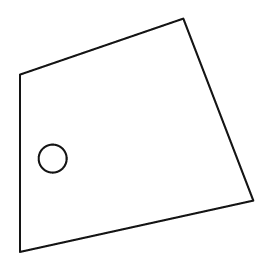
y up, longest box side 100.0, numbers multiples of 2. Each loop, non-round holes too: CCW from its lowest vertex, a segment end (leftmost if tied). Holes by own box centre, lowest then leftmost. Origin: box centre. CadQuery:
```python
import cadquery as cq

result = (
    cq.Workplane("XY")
    .moveTo(-50.0, -50.0)
    .lineTo(50.0, -28.0)
    .lineTo(20.0, 50.0)
    .lineTo(-50.0, 26.0)
    .close()
    .moveTo(-36.0, -10.0)
    .circle(6.0)
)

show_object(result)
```